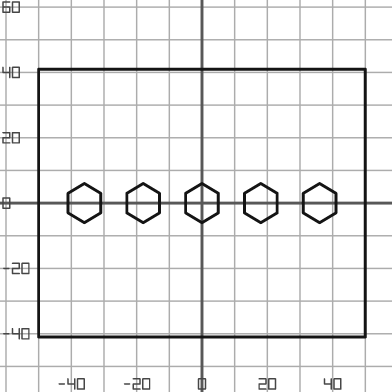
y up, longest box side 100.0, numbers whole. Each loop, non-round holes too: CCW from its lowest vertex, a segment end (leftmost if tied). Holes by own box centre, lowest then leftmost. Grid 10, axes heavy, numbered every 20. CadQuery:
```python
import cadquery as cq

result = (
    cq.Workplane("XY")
    .moveTo(-50.0, -41.0)
    .lineTo(50.0, -41.0)
    .lineTo(50.0, 41.0)
    .lineTo(-50.0, 41.0)
    .close()
    .moveTo(-36.0, -6.0)
    .lineTo(-31.0, -3.0)
    .lineTo(-31.0, 3.0)
    .lineTo(-36.0, 6.0)
    .lineTo(-41.0, 3.0)
    .lineTo(-41.0, -3.0)
    .close()
    .moveTo(-18.0, -6.0)
    .lineTo(-13.0, -3.0)
    .lineTo(-13.0, 3.0)
    .lineTo(-18.0, 6.0)
    .lineTo(-23.0, 3.0)
    .lineTo(-23.0, -3.0)
    .close()
    .moveTo(0.0, -6.0)
    .lineTo(5.0, -3.0)
    .lineTo(5.0, 3.0)
    .lineTo(0.0, 6.0)
    .lineTo(-5.0, 3.0)
    .lineTo(-5.0, -3.0)
    .close()
    .moveTo(18.0, -6.0)
    .lineTo(23.0, -3.0)
    .lineTo(23.0, 3.0)
    .lineTo(18.0, 6.0)
    .lineTo(13.0, 3.0)
    .lineTo(13.0, -3.0)
    .close()
    .moveTo(36.0, -6.0)
    .lineTo(41.0, -3.0)
    .lineTo(41.0, 3.0)
    .lineTo(36.0, 6.0)
    .lineTo(31.0, 3.0)
    .lineTo(31.0, -3.0)
    .close()
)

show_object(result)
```